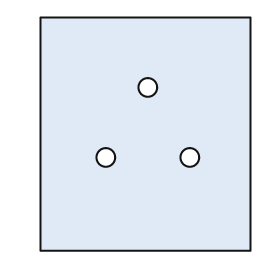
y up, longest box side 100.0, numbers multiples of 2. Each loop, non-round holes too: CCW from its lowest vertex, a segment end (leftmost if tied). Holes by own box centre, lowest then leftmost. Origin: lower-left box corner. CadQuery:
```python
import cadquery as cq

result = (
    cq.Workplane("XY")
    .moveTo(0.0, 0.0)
    .lineTo(90.0, 0.0)
    .lineTo(90.0, 100.0)
    .lineTo(0.0, 100.0)
    .close()
    .moveTo(28.0, 40.0)
    .circle(4.0)
    .moveTo(64.0, 40.0)
    .circle(4.0)
    .moveTo(46.0, 70.0)
    .circle(4.0)
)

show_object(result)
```